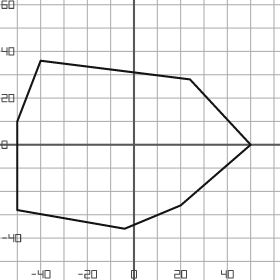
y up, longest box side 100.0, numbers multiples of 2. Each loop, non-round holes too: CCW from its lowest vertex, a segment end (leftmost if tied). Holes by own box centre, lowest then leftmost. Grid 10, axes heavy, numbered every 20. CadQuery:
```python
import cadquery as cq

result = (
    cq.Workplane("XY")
    .moveTo(-4.0, -36.0)
    .lineTo(20.0, -26.0)
    .lineTo(50.0, 0.0)
    .lineTo(24.0, 28.0)
    .lineTo(-40.0, 36.0)
    .lineTo(-50.0, 10.0)
    .lineTo(-50.0, -28.0)
    .close()
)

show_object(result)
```